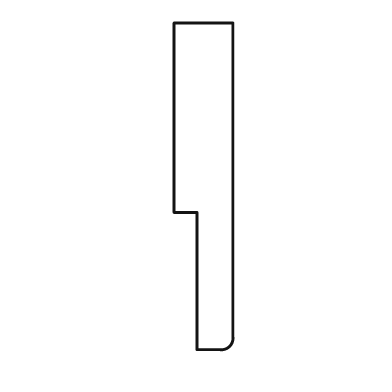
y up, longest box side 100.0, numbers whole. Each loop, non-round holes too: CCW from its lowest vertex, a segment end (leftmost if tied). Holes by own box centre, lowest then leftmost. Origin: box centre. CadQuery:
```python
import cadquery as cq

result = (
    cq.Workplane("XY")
    .moveTo(-2.0, -50.0)
    .lineTo(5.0, -50.0)
    .threePointArc((8.0, -49.0), (9.0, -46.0))
    .lineTo(9.0, 50.0)
    .lineTo(-9.0, 50.0)
    .lineTo(-9.0, -8.0)
    .lineTo(-2.0, -8.0)
    .close()
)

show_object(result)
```